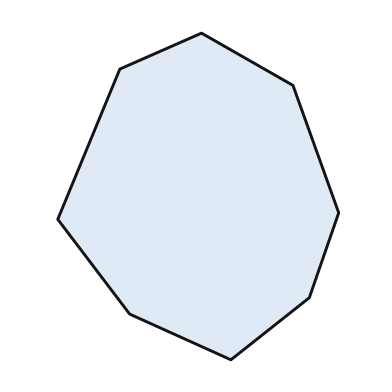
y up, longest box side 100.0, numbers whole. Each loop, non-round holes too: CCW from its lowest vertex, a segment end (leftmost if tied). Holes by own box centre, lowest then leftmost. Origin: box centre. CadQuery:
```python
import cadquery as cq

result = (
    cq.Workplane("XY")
    .moveTo(10.0, -50.0)
    .lineTo(34.0, -31.0)
    .lineTo(43.0, -5.0)
    .lineTo(29.0, 34.0)
    .lineTo(1.0, 50.0)
    .lineTo(-24.0, 39.0)
    .lineTo(-43.0, -7.0)
    .lineTo(-21.0, -36.0)
    .close()
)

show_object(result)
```